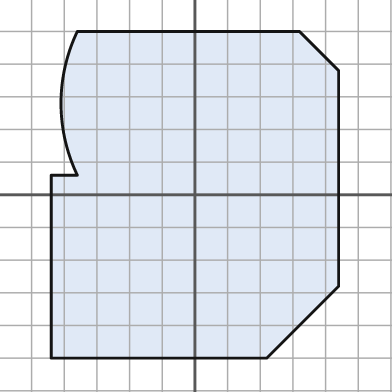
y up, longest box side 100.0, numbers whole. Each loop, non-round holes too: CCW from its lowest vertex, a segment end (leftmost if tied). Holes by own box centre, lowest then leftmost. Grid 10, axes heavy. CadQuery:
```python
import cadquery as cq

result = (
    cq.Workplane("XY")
    .moveTo(-44.0, -50.0)
    .lineTo(22.0, -50.0)
    .lineTo(44.0, -28.0)
    .lineTo(44.0, 38.0)
    .lineTo(32.0, 50.0)
    .lineTo(-36.0, 50.0)
    .threePointArc((-41.0, 28.0), (-36.0, 6.0))
    .lineTo(-44.0, 6.0)
    .close()
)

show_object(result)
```